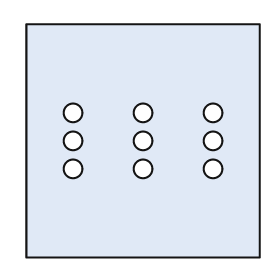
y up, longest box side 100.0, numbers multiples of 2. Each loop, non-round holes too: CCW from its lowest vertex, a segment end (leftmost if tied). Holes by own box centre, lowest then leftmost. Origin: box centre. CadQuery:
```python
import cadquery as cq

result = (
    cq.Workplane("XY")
    .moveTo(-50.0, -50.0)
    .lineTo(50.0, -50.0)
    .lineTo(50.0, 50.0)
    .lineTo(-50.0, 50.0)
    .close()
    .moveTo(-30.0, -12.0)
    .circle(4.0)
    .moveTo(0.0, -12.0)
    .circle(4.0)
    .moveTo(30.0, -12.0)
    .circle(4.0)
    .moveTo(-30.0, 0.0)
    .circle(4.0)
    .moveTo(0.0, 0.0)
    .circle(4.0)
    .moveTo(30.0, 0.0)
    .circle(4.0)
    .moveTo(-30.0, 12.0)
    .circle(4.0)
    .moveTo(0.0, 12.0)
    .circle(4.0)
    .moveTo(30.0, 12.0)
    .circle(4.0)
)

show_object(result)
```